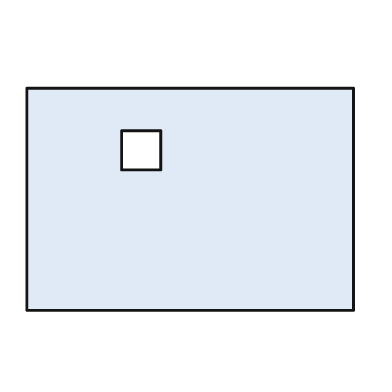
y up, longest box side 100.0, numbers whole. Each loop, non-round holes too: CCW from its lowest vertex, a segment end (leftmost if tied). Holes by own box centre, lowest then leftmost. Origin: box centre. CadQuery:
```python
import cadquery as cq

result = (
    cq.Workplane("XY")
    .moveTo(-50.0, -34.0)
    .lineTo(50.0, -34.0)
    .lineTo(50.0, 34.0)
    .lineTo(-50.0, 34.0)
    .close()
    .moveTo(-21.0, 9.0)
    .lineTo(-9.0, 9.0)
    .lineTo(-9.0, 21.0)
    .lineTo(-21.0, 21.0)
    .close()
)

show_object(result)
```